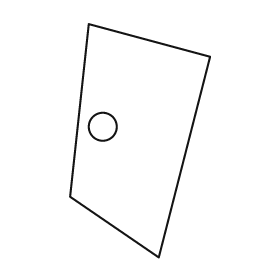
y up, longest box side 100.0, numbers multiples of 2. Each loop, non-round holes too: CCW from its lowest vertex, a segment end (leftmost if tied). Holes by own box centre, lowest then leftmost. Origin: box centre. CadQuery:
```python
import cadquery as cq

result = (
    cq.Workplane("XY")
    .moveTo(8.0, -50.0)
    .lineTo(30.0, 36.0)
    .lineTo(-22.0, 50.0)
    .lineTo(-30.0, -24.0)
    .close()
    .moveTo(-16.0, 6.0)
    .circle(6.0)
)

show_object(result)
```